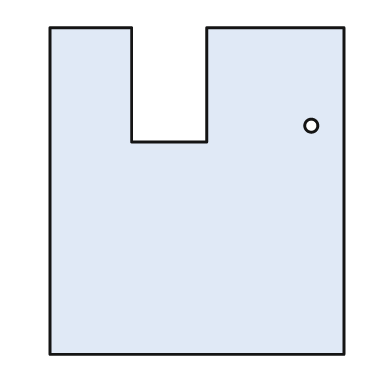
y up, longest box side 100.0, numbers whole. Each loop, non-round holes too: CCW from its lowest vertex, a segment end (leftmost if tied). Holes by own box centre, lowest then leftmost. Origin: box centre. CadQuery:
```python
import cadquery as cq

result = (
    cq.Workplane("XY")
    .moveTo(-45.0, -50.0)
    .lineTo(45.0, -50.0)
    .lineTo(45.0, 50.0)
    .lineTo(3.0, 50.0)
    .lineTo(3.0, 15.0)
    .lineTo(-20.0, 15.0)
    .lineTo(-20.0, 50.0)
    .lineTo(-45.0, 50.0)
    .close()
    .moveTo(35.0, 20.0)
    .circle(2.0)
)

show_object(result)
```